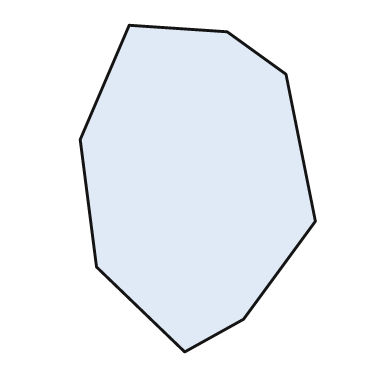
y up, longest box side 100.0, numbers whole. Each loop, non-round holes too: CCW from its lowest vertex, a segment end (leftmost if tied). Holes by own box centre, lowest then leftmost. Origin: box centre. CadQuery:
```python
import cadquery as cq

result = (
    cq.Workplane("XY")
    .moveTo(-4.0, -50.0)
    .lineTo(14.0, -40.0)
    .lineTo(36.0, -10.0)
    .lineTo(27.0, 35.0)
    .lineTo(9.0, 48.0)
    .lineTo(-21.0, 50.0)
    .lineTo(-36.0, 15.0)
    .lineTo(-31.0, -24.0)
    .close()
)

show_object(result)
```